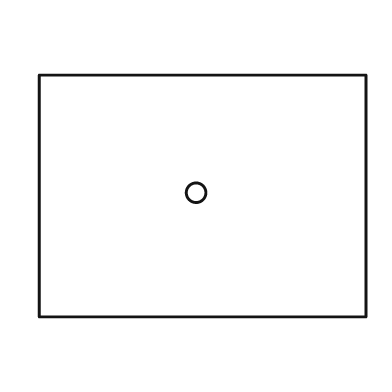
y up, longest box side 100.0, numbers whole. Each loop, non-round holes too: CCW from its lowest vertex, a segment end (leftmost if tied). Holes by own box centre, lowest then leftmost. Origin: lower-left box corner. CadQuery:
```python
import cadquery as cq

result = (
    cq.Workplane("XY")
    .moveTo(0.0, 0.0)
    .lineTo(100.0, 0.0)
    .lineTo(100.0, 74.0)
    .lineTo(0.0, 74.0)
    .close()
    .moveTo(48.0, 38.0)
    .circle(3.0)
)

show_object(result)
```